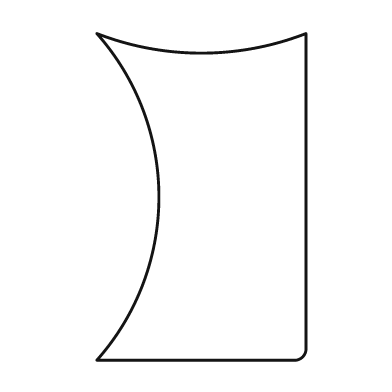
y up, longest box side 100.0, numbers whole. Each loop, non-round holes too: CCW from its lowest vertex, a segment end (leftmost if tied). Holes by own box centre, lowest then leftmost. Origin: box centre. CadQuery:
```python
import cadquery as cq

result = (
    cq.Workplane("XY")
    .moveTo(-32.0, -50.0)
    .lineTo(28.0, -50.0)
    .threePointArc((31.0, -49.0), (32.0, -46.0))
    .lineTo(32.0, 50.0)
    .threePointArc((0.0, 44.0), (-32.0, 50.0))
    .threePointArc((-13.0, 0.0), (-32.0, -50.0))
    .close()
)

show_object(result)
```